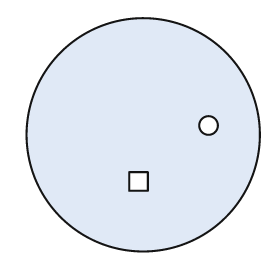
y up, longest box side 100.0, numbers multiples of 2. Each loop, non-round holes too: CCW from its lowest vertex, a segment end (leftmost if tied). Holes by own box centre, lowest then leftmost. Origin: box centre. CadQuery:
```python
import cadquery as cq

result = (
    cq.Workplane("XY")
    .moveTo(0.0, 0.0)
    .circle(50.0)
    .moveTo(-6.0, -24.0)
    .lineTo(2.0, -24.0)
    .lineTo(2.0, -16.0)
    .lineTo(-6.0, -16.0)
    .close()
    .moveTo(28.0, 4.0)
    .circle(4.0)
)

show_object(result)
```